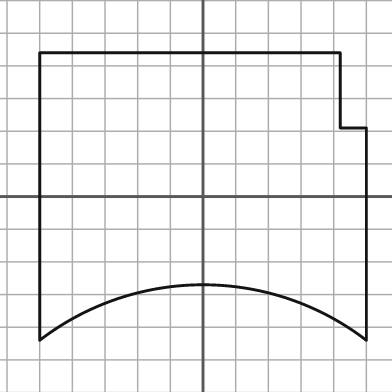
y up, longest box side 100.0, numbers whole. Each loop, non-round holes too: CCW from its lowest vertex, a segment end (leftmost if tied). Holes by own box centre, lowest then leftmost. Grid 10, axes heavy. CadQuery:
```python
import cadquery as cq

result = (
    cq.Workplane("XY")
    .moveTo(-50.0, -44.0)
    .threePointArc((0.0, -27.0), (50.0, -44.0))
    .lineTo(50.0, 21.0)
    .lineTo(42.0, 21.0)
    .lineTo(42.0, 44.0)
    .lineTo(-50.0, 44.0)
    .close()
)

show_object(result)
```